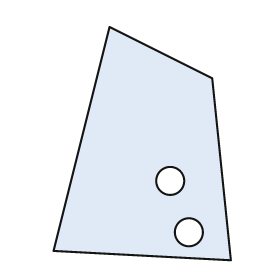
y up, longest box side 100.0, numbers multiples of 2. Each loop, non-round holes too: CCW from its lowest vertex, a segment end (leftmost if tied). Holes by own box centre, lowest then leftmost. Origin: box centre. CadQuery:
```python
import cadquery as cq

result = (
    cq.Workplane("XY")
    .moveTo(38.0, -50.0)
    .lineTo(30.0, 28.0)
    .lineTo(-14.0, 50.0)
    .lineTo(-38.0, -46.0)
    .close()
    .moveTo(20.0, -38.0)
    .circle(6.0)
    .moveTo(12.0, -16.0)
    .circle(6.0)
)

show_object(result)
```